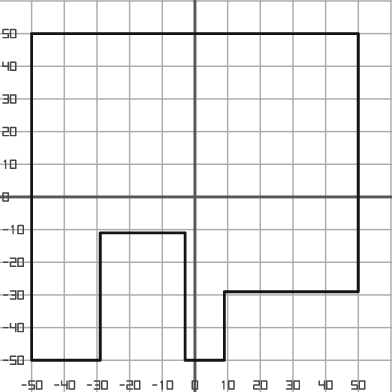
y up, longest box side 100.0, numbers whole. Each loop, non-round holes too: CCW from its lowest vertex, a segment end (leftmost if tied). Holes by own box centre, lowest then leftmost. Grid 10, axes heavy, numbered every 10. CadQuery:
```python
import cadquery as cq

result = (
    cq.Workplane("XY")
    .moveTo(-50.0, -50.0)
    .lineTo(-29.0, -50.0)
    .lineTo(-29.0, -11.0)
    .lineTo(-3.0, -11.0)
    .lineTo(-3.0, -50.0)
    .lineTo(9.0, -50.0)
    .lineTo(9.0, -29.0)
    .lineTo(50.0, -29.0)
    .lineTo(50.0, 50.0)
    .lineTo(-50.0, 50.0)
    .close()
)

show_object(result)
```